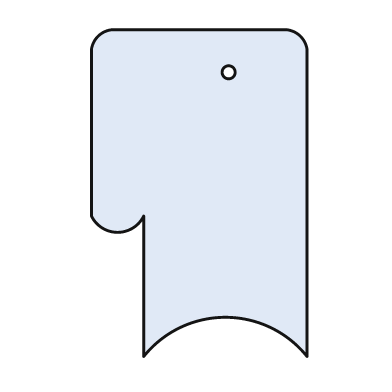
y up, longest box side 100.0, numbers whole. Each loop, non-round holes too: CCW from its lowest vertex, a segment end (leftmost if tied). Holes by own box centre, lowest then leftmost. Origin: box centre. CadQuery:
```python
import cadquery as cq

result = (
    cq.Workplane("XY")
    .moveTo(-17.0, -50.0)
    .threePointArc((8.0, -38.0), (33.0, -50.0))
    .lineTo(33.0, 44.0)
    .threePointArc((31.0, 48.0), (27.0, 50.0))
    .lineTo(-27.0, 50.0)
    .threePointArc((-31.0, 48.0), (-33.0, 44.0))
    .lineTo(-33.0, -7.0)
    .threePointArc((-25.0, -12.0), (-17.0, -7.0))
    .close()
    .moveTo(9.0, 37.0)
    .circle(2.0)
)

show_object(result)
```